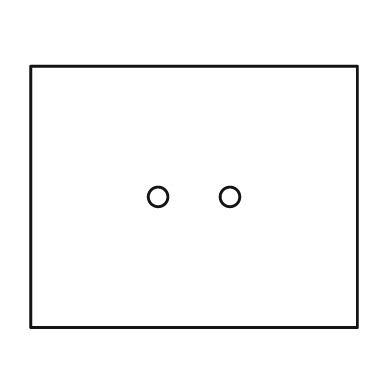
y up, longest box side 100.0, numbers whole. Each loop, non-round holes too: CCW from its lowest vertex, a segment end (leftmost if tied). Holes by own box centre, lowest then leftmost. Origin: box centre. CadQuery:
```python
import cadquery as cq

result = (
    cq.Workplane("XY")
    .moveTo(-50.0, -40.0)
    .lineTo(50.0, -40.0)
    .lineTo(50.0, 40.0)
    .lineTo(-50.0, 40.0)
    .close()
    .moveTo(-11.0, 0.0)
    .circle(3.0)
    .moveTo(11.0, 0.0)
    .circle(3.0)
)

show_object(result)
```